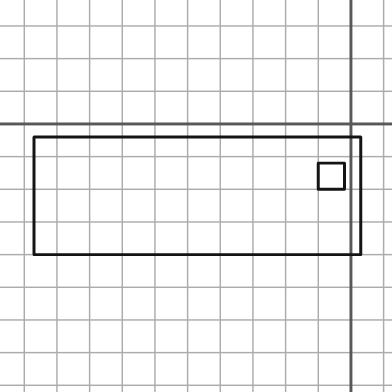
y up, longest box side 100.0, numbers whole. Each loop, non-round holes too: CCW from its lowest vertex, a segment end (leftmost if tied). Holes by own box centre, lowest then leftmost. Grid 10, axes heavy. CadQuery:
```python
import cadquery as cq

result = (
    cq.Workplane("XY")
    .moveTo(-97.0, -40.0)
    .lineTo(3.0, -40.0)
    .lineTo(3.0, -4.0)
    .lineTo(-97.0, -4.0)
    .close()
    .moveTo(-10.0, -20.0)
    .lineTo(-2.0, -20.0)
    .lineTo(-2.0, -12.0)
    .lineTo(-10.0, -12.0)
    .close()
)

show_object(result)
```